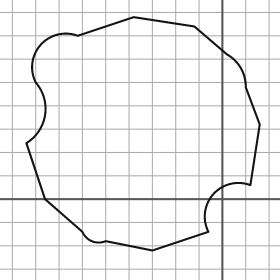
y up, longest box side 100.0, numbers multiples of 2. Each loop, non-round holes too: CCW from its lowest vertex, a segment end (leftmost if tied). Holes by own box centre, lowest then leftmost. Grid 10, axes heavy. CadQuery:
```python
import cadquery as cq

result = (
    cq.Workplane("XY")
    .moveTo(-30.0, -22.0)
    .lineTo(-6.0, -14.0)
    .threePointArc((-4.0, 2.0), (12.0, 6.0))
    .lineTo(16.0, 32.0)
    .lineTo(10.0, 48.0)
    .threePointArc((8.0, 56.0), (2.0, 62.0))
    .lineTo(-12.0, 74.0)
    .lineTo(-38.0, 78.0)
    .lineTo(-62.0, 70.0)
    .threePointArc((-78.0, 66.0), (-80.0, 50.0))
    .threePointArc((-76.0, 36.0), (-84.0, 24.0))
    .lineTo(-76.0, 0.0)
    .lineTo(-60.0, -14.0)
    .threePointArc((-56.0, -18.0), (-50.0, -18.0))
    .close()
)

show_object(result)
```